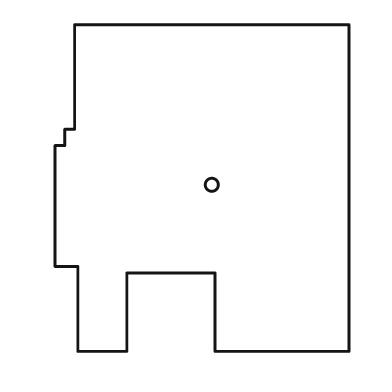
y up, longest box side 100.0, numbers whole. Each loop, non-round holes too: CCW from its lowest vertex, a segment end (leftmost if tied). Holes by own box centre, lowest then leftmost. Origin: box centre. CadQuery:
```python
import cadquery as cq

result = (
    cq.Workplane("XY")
    .moveTo(-38.0, -50.0)
    .lineTo(-23.0, -50.0)
    .lineTo(-23.0, -26.0)
    .lineTo(4.0, -26.0)
    .lineTo(4.0, -50.0)
    .lineTo(45.0, -50.0)
    .lineTo(45.0, 50.0)
    .lineTo(-39.0, 50.0)
    .lineTo(-39.0, 18.0)
    .lineTo(-42.0, 18.0)
    .lineTo(-42.0, 13.0)
    .lineTo(-45.0, 13.0)
    .lineTo(-45.0, -24.0)
    .lineTo(-38.0, -24.0)
    .close()
    .moveTo(3.0, 1.0)
    .circle(2.0)
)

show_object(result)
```